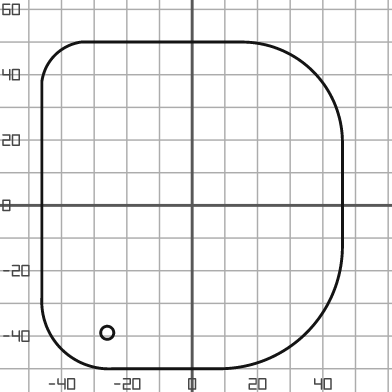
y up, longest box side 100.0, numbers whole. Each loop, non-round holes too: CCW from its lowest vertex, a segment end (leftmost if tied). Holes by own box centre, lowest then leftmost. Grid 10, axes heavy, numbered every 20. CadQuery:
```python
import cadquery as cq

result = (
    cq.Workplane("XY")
    .moveTo(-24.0, -50.0)
    .lineTo(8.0, -50.0)
    .threePointArc((35.0, -39.0), (46.0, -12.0))
    .lineTo(46.0, 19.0)
    .threePointArc((37.0, 41.0), (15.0, 50.0))
    .lineTo(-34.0, 50.0)
    .threePointArc((-42.0, 46.0), (-46.0, 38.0))
    .lineTo(-46.0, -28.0)
    .threePointArc((-40.0, -44.0), (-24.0, -50.0))
    .close()
    .moveTo(-26.0, -39.0)
    .circle(2.0)
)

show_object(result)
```